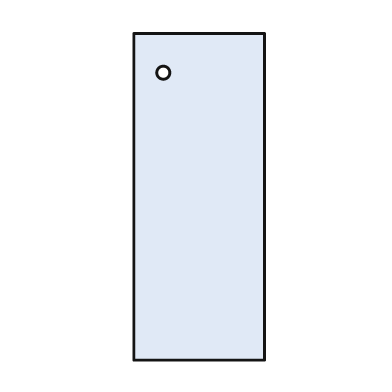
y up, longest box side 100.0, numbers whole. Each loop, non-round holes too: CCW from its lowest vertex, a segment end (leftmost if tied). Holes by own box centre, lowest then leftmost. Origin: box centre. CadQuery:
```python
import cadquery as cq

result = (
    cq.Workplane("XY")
    .moveTo(-20.0, -50.0)
    .lineTo(20.0, -50.0)
    .lineTo(20.0, 50.0)
    .lineTo(-20.0, 50.0)
    .close()
    .moveTo(-11.0, 38.0)
    .circle(2.0)
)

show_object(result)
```